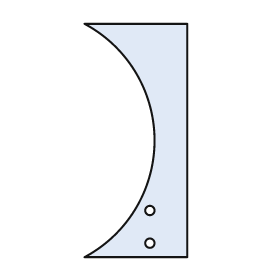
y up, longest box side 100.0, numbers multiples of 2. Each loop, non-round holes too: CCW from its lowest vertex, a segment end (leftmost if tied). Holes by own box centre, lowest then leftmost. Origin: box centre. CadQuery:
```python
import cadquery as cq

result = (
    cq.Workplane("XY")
    .moveTo(-22.0, -50.0)
    .lineTo(22.0, -50.0)
    .lineTo(22.0, 50.0)
    .lineTo(-22.0, 50.0)
    .threePointArc((8.0, 0.0), (-22.0, -50.0))
    .close()
    .moveTo(6.0, -44.0)
    .circle(2.0)
    .moveTo(6.0, -30.0)
    .circle(2.0)
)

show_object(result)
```